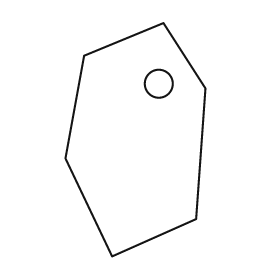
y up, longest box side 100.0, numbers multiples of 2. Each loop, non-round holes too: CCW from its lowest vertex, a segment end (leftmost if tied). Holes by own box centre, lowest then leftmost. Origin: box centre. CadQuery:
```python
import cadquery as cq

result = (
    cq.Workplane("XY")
    .moveTo(-10.0, -50.0)
    .lineTo(26.0, -34.0)
    .lineTo(30.0, 22.0)
    .lineTo(12.0, 50.0)
    .lineTo(-22.0, 36.0)
    .lineTo(-30.0, -8.0)
    .close()
    .moveTo(10.0, 24.0)
    .circle(6.0)
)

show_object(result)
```